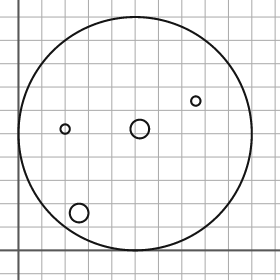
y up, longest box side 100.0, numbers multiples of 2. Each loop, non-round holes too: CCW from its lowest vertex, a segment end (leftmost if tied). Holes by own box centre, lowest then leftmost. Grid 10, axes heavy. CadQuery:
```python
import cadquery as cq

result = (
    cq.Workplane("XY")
    .moveTo(50.0, 50.0)
    .circle(50.0)
    .moveTo(26.0, 16.0)
    .circle(4.0)
    .moveTo(20.0, 52.0)
    .circle(2.0)
    .moveTo(52.0, 52.0)
    .circle(4.0)
    .moveTo(76.0, 64.0)
    .circle(2.0)
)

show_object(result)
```